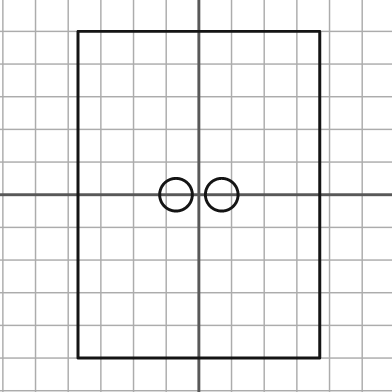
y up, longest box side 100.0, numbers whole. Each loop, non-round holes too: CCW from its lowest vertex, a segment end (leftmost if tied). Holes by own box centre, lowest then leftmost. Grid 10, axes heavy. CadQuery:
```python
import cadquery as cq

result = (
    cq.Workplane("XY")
    .moveTo(-37.0, -50.0)
    .lineTo(37.0, -50.0)
    .lineTo(37.0, 50.0)
    .lineTo(-37.0, 50.0)
    .close()
    .moveTo(-7.0, 0.0)
    .circle(5.0)
    .moveTo(7.0, 0.0)
    .circle(5.0)
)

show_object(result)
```